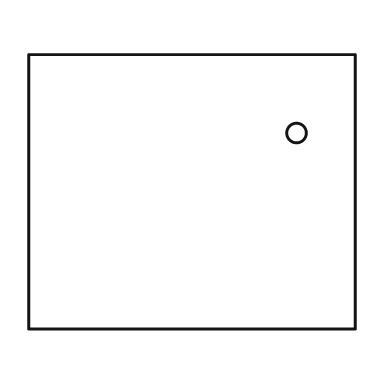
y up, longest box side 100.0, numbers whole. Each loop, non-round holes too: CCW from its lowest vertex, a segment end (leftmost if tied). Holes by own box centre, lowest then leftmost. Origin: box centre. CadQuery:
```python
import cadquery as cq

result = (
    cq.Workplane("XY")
    .moveTo(-50.0, -42.0)
    .lineTo(50.0, -42.0)
    .lineTo(50.0, 42.0)
    .lineTo(-50.0, 42.0)
    .close()
    .moveTo(32.0, 18.0)
    .circle(3.0)
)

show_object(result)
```